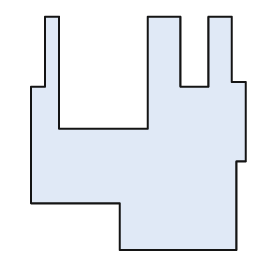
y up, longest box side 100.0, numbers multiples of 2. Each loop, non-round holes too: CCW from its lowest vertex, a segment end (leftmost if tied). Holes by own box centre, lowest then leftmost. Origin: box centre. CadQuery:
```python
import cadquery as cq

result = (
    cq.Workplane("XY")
    .moveTo(-8.0, -50.0)
    .lineTo(42.0, -50.0)
    .lineTo(42.0, -12.0)
    .lineTo(46.0, -12.0)
    .lineTo(46.0, 22.0)
    .lineTo(40.0, 22.0)
    .lineTo(40.0, 50.0)
    .lineTo(30.0, 50.0)
    .lineTo(30.0, 20.0)
    .lineTo(18.0, 20.0)
    .lineTo(18.0, 50.0)
    .lineTo(4.0, 50.0)
    .lineTo(4.0, 2.0)
    .lineTo(-34.0, 2.0)
    .lineTo(-34.0, 50.0)
    .lineTo(-40.0, 50.0)
    .lineTo(-40.0, 20.0)
    .lineTo(-46.0, 20.0)
    .lineTo(-46.0, -30.0)
    .lineTo(-8.0, -30.0)
    .close()
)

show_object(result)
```